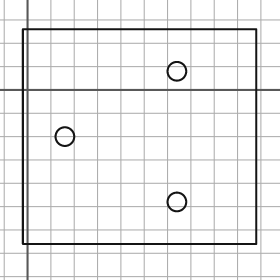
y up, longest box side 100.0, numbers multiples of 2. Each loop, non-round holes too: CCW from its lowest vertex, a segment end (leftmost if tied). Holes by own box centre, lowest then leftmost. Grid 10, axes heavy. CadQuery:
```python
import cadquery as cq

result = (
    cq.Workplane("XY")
    .moveTo(-2.0, -66.0)
    .lineTo(98.0, -66.0)
    .lineTo(98.0, 26.0)
    .lineTo(-2.0, 26.0)
    .close()
    .moveTo(64.0, -48.0)
    .circle(4.0)
    .moveTo(16.0, -20.0)
    .circle(4.0)
    .moveTo(64.0, 8.0)
    .circle(4.0)
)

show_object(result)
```